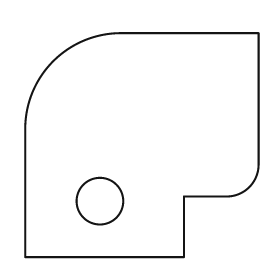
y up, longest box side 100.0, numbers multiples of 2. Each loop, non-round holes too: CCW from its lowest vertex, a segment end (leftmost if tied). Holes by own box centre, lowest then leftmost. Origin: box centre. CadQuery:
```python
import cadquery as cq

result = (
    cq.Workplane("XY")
    .moveTo(-50.0, -48.0)
    .lineTo(18.0, -48.0)
    .lineTo(18.0, -22.0)
    .lineTo(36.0, -22.0)
    .threePointArc((46.0, -18.0), (50.0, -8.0))
    .lineTo(50.0, 48.0)
    .lineTo(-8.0, 48.0)
    .threePointArc((-38.0, 36.0), (-50.0, 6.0))
    .close()
    .moveTo(-18.0, -24.0)
    .circle(10.0)
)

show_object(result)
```